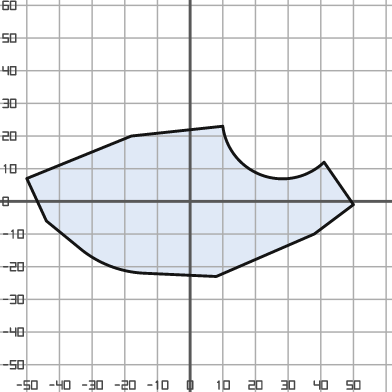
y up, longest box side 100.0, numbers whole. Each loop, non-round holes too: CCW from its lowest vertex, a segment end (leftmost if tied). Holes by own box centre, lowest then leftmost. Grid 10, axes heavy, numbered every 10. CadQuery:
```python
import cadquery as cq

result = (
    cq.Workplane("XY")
    .moveTo(8.0, -23.0)
    .lineTo(38.0, -10.0)
    .lineTo(50.0, -1.0)
    .lineTo(41.0, 12.0)
    .threePointArc((22.0, 8.0), (10.0, 23.0))
    .lineTo(-18.0, 20.0)
    .lineTo(-50.0, 7.0)
    .lineTo(-44.0, -6.0)
    .lineTo(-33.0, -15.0)
    .threePointArc((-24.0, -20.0), (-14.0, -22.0))
    .close()
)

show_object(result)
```